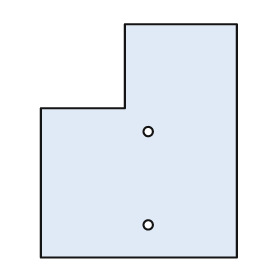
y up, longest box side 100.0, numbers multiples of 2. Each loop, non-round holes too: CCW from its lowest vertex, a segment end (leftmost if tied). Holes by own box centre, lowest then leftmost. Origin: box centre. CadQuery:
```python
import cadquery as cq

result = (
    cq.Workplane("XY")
    .moveTo(-42.0, -50.0)
    .lineTo(42.0, -50.0)
    .lineTo(42.0, 50.0)
    .lineTo(-6.0, 50.0)
    .lineTo(-6.0, 14.0)
    .lineTo(-42.0, 14.0)
    .close()
    .moveTo(4.0, -36.0)
    .circle(2.0)
    .moveTo(4.0, 4.0)
    .circle(2.0)
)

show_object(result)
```